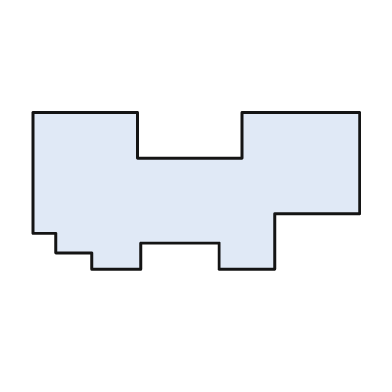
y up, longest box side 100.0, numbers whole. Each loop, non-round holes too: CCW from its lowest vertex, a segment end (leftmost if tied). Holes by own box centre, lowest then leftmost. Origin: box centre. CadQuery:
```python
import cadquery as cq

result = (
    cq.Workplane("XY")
    .moveTo(-32.0, -24.0)
    .lineTo(-17.0, -24.0)
    .lineTo(-17.0, -16.0)
    .lineTo(7.0, -16.0)
    .lineTo(7.0, -24.0)
    .lineTo(24.0, -24.0)
    .lineTo(24.0, -7.0)
    .lineTo(50.0, -7.0)
    .lineTo(50.0, 24.0)
    .lineTo(14.0, 24.0)
    .lineTo(14.0, 10.0)
    .lineTo(-18.0, 10.0)
    .lineTo(-18.0, 24.0)
    .lineTo(-50.0, 24.0)
    .lineTo(-50.0, -13.0)
    .lineTo(-43.0, -13.0)
    .lineTo(-43.0, -19.0)
    .lineTo(-32.0, -19.0)
    .close()
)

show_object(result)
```